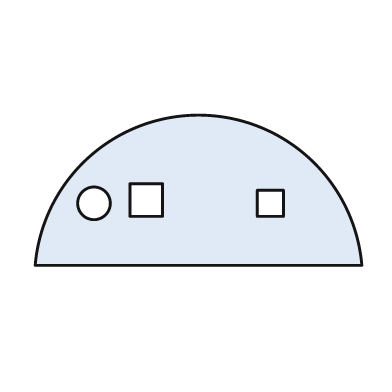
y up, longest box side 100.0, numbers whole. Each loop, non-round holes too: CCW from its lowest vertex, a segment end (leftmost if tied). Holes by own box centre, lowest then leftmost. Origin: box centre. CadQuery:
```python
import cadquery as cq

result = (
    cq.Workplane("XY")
    .moveTo(-50.0, -23.0)
    .lineTo(50.0, -23.0)
    .threePointArc((0.0, 23.0), (-50.0, -23.0))
    .close()
    .moveTo(-32.0, -4.0)
    .circle(5.0)
    .moveTo(18.0, -8.0)
    .lineTo(26.0, -8.0)
    .lineTo(26.0, 0.0)
    .lineTo(18.0, 0.0)
    .close()
    .moveTo(-21.0, -8.0)
    .lineTo(-11.0, -8.0)
    .lineTo(-11.0, 2.0)
    .lineTo(-21.0, 2.0)
    .close()
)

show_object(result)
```